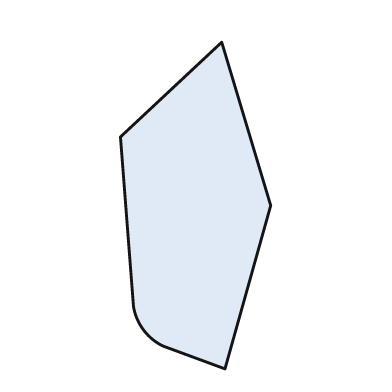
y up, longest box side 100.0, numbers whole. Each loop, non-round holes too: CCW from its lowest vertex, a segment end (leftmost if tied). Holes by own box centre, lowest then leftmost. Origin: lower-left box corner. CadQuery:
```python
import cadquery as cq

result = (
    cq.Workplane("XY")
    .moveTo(32.0, 0.0)
    .lineTo(46.0, 50.0)
    .lineTo(31.0, 100.0)
    .lineTo(0.0, 71.0)
    .lineTo(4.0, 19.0)
    .threePointArc((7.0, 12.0), (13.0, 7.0))
    .close()
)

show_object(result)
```